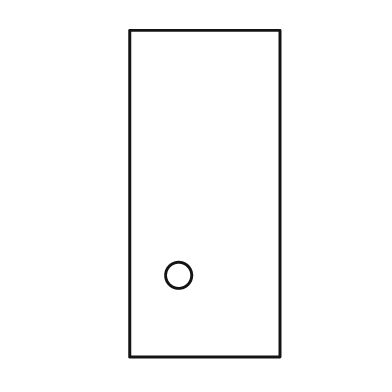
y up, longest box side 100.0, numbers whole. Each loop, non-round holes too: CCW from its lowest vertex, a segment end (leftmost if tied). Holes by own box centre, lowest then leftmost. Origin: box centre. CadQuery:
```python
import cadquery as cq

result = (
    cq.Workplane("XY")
    .moveTo(-23.0, -50.0)
    .lineTo(23.0, -50.0)
    .lineTo(23.0, 50.0)
    .lineTo(-23.0, 50.0)
    .close()
    .moveTo(-8.0, -25.0)
    .circle(4.0)
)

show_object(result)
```